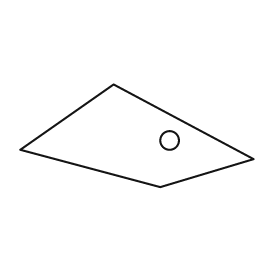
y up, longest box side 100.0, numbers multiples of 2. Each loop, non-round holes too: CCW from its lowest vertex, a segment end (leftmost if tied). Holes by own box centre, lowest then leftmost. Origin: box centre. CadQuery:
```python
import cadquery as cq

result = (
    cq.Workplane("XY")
    .moveTo(10.0, -22.0)
    .lineTo(50.0, -10.0)
    .lineTo(-10.0, 22.0)
    .lineTo(-50.0, -6.0)
    .close()
    .moveTo(14.0, -2.0)
    .circle(4.0)
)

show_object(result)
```